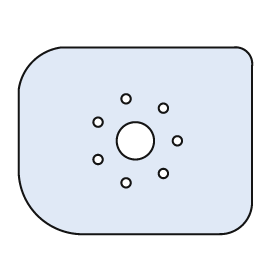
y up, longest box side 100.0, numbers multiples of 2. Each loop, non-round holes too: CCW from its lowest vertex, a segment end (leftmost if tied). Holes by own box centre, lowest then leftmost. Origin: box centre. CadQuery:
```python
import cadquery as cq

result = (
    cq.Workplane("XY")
    .moveTo(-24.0, -40.0)
    .lineTo(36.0, -40.0)
    .threePointArc((46.0, -36.0), (50.0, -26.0))
    .lineTo(50.0, 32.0)
    .threePointArc((48.0, 38.0), (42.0, 40.0))
    .lineTo(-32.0, 40.0)
    .threePointArc((-44.0, 34.0), (-50.0, 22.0))
    .lineTo(-50.0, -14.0)
    .threePointArc((-42.0, -32.0), (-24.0, -40.0))
    .close()
    .moveTo(-4.0, -18.0)
    .circle(2.0)
    .moveTo(12.0, -14.0)
    .circle(2.0)
    .moveTo(-16.0, -8.0)
    .circle(2.0)
    .moveTo(0.0, 0.0)
    .circle(8.0)
    .moveTo(18.0, 0.0)
    .circle(2.0)
    .moveTo(-16.0, 8.0)
    .circle(2.0)
    .moveTo(12.0, 14.0)
    .circle(2.0)
    .moveTo(-4.0, 18.0)
    .circle(2.0)
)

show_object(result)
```